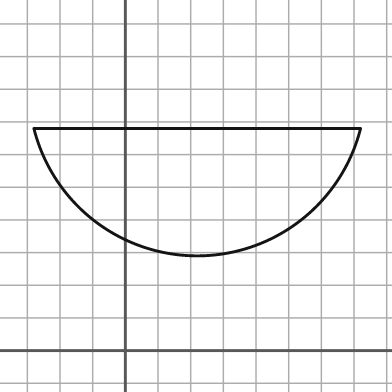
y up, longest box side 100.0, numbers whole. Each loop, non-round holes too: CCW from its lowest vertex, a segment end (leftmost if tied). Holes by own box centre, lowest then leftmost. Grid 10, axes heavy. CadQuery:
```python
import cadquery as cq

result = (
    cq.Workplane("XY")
    .moveTo(-28.0, 68.0)
    .threePointArc((22.0, 29.0), (72.0, 68.0))
    .close()
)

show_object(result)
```